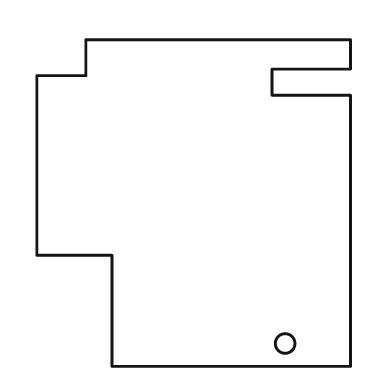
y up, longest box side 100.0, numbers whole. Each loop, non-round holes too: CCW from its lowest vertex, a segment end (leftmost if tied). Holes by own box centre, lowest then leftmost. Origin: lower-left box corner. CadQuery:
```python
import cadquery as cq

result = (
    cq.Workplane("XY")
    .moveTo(23.0, 0.0)
    .lineTo(96.0, 0.0)
    .lineTo(96.0, 83.0)
    .lineTo(72.0, 83.0)
    .lineTo(72.0, 91.0)
    .lineTo(96.0, 91.0)
    .lineTo(96.0, 100.0)
    .lineTo(15.0, 100.0)
    .lineTo(15.0, 89.0)
    .lineTo(0.0, 89.0)
    .lineTo(0.0, 34.0)
    .lineTo(23.0, 34.0)
    .close()
    .moveTo(76.0, 7.0)
    .circle(3.0)
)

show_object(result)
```